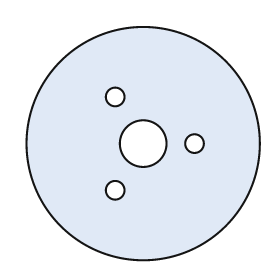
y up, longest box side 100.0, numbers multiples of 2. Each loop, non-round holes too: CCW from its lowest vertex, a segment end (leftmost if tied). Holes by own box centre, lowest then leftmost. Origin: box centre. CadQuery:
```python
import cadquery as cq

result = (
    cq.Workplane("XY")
    .moveTo(0.0, 0.0)
    .circle(50.0)
    .moveTo(-12.0, -20.0)
    .circle(4.0)
    .moveTo(0.0, 0.0)
    .circle(10.0)
    .moveTo(22.0, 0.0)
    .circle(4.0)
    .moveTo(-12.0, 20.0)
    .circle(4.0)
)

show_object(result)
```